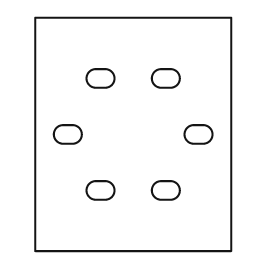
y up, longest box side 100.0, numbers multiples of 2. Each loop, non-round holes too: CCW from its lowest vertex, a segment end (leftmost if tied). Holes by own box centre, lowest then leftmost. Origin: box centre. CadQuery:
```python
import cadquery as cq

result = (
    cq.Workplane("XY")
    .moveTo(-42.0, -50.0)
    .lineTo(42.0, -50.0)
    .lineTo(42.0, 50.0)
    .lineTo(-42.0, 50.0)
    .close()
    .moveTo(-16.0, -28.0)
    .lineTo(-12.0, -28.0)
    .threePointArc((-8.0, -24.0), (-12.0, -20.0))
    .lineTo(-16.0, -20.0)
    .threePointArc((-20.0, -24.0), (-16.0, -28.0))
    .close()
    .moveTo(12.0, -28.0)
    .lineTo(16.0, -28.0)
    .threePointArc((20.0, -24.0), (16.0, -20.0))
    .lineTo(12.0, -20.0)
    .threePointArc((8.0, -24.0), (12.0, -28.0))
    .close()
    .moveTo(-30.0, -4.0)
    .lineTo(-26.0, -4.0)
    .threePointArc((-22.0, 0.0), (-26.0, 4.0))
    .lineTo(-30.0, 4.0)
    .threePointArc((-34.0, 0.0), (-30.0, -4.0))
    .close()
    .moveTo(26.0, -4.0)
    .lineTo(30.0, -4.0)
    .threePointArc((34.0, 0.0), (30.0, 4.0))
    .lineTo(26.0, 4.0)
    .threePointArc((22.0, 0.0), (26.0, -4.0))
    .close()
    .moveTo(-16.0, 20.0)
    .lineTo(-12.0, 20.0)
    .threePointArc((-8.0, 24.0), (-12.0, 28.0))
    .lineTo(-16.0, 28.0)
    .threePointArc((-20.0, 24.0), (-16.0, 20.0))
    .close()
    .moveTo(12.0, 20.0)
    .lineTo(16.0, 20.0)
    .threePointArc((20.0, 24.0), (16.0, 28.0))
    .lineTo(12.0, 28.0)
    .threePointArc((8.0, 24.0), (12.0, 20.0))
    .close()
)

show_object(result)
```